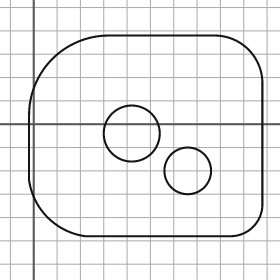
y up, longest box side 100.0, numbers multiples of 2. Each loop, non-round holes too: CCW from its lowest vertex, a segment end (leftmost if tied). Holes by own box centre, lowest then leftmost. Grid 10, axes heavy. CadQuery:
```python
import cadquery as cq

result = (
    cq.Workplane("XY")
    .moveTo(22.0, -48.0)
    .lineTo(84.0, -48.0)
    .threePointArc((94.0, -44.0), (98.0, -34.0))
    .lineTo(98.0, 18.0)
    .threePointArc((92.0, 32.0), (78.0, 38.0))
    .lineTo(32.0, 38.0)
    .threePointArc((8.0, 28.0), (-2.0, 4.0))
    .lineTo(-2.0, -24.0)
    .threePointArc((6.0, -40.0), (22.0, -48.0))
    .close()
    .moveTo(66.0, -20.0)
    .circle(10.0)
    .moveTo(42.0, -4.0)
    .circle(12.0)
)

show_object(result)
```